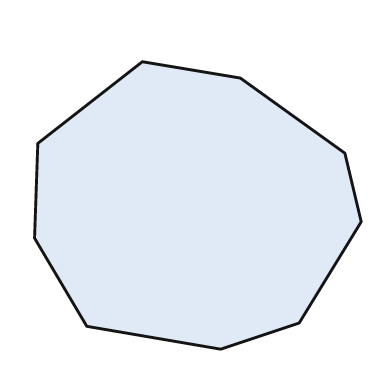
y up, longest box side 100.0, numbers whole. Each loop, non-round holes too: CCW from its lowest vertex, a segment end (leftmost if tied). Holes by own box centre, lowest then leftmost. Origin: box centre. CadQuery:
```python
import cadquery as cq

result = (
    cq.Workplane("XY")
    .moveTo(7.0, -44.0)
    .lineTo(31.0, -36.0)
    .lineTo(50.0, -5.0)
    .lineTo(45.0, 16.0)
    .lineTo(13.0, 39.0)
    .lineTo(-17.0, 44.0)
    .lineTo(-49.0, 19.0)
    .lineTo(-50.0, -10.0)
    .lineTo(-34.0, -37.0)
    .close()
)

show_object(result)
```